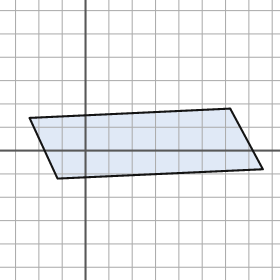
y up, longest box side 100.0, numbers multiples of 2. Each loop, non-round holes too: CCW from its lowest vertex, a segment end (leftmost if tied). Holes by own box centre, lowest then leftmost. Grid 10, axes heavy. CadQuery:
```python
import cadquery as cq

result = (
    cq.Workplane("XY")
    .moveTo(-12.0, -12.0)
    .lineTo(76.0, -8.0)
    .lineTo(62.0, 18.0)
    .lineTo(-24.0, 14.0)
    .close()
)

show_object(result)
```